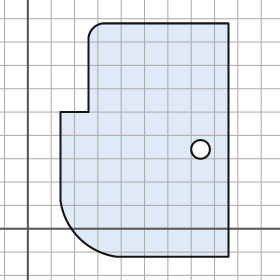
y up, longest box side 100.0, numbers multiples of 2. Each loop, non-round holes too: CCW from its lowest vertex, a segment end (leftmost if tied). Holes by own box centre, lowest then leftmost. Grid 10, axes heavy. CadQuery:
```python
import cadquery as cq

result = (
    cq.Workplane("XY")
    .moveTo(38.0, -12.0)
    .lineTo(86.0, -12.0)
    .lineTo(86.0, 88.0)
    .lineTo(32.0, 88.0)
    .threePointArc((28.0, 86.0), (26.0, 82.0))
    .lineTo(26.0, 50.0)
    .lineTo(14.0, 50.0)
    .lineTo(14.0, 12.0)
    .threePointArc((22.0, -4.0), (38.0, -12.0))
    .close()
    .moveTo(74.0, 34.0)
    .circle(4.0)
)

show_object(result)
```